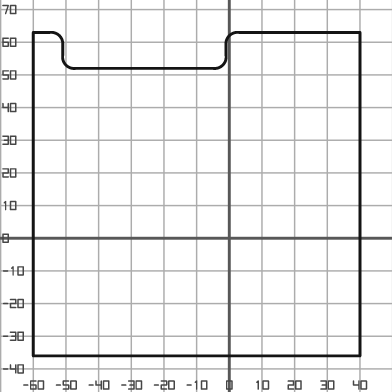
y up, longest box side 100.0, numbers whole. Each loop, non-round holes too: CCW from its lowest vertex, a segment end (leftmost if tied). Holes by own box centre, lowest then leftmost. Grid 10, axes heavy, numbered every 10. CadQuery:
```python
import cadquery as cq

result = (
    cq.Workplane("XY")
    .moveTo(-60.0, -36.0)
    .lineTo(40.0, -36.0)
    .lineTo(40.0, 63.0)
    .lineTo(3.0, 63.0)
    .threePointArc((0.0, 62.0), (-1.0, 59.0))
    .lineTo(-1.0, 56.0)
    .threePointArc((-2.0, 53.0), (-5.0, 52.0))
    .lineTo(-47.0, 52.0)
    .threePointArc((-50.0, 53.0), (-51.0, 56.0))
    .lineTo(-51.0, 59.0)
    .threePointArc((-52.0, 62.0), (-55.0, 63.0))
    .lineTo(-60.0, 63.0)
    .close()
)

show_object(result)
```